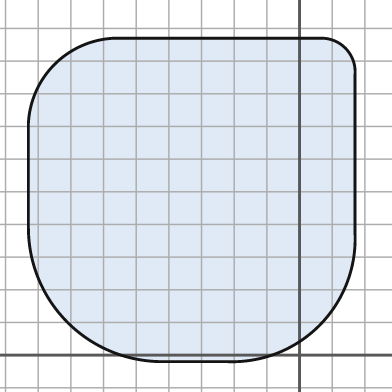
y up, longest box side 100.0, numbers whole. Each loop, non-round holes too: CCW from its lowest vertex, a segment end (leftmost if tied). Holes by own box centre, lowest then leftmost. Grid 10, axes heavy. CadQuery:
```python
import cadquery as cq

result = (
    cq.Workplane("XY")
    .moveTo(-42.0, -2.0)
    .lineTo(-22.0, -2.0)
    .threePointArc((6.0, 9.0), (17.0, 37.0))
    .lineTo(17.0, 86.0)
    .threePointArc((14.0, 94.0), (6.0, 97.0))
    .lineTo(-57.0, 97.0)
    .threePointArc((-75.0, 89.0), (-83.0, 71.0))
    .lineTo(-83.0, 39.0)
    .threePointArc((-71.0, 10.0), (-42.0, -2.0))
    .close()
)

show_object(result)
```